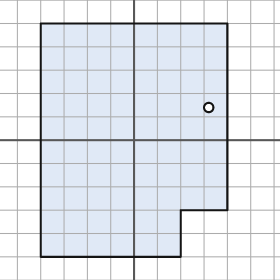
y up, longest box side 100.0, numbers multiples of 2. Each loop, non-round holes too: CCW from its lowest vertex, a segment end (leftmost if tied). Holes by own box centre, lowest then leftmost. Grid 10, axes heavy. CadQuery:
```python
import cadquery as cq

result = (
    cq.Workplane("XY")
    .moveTo(-40.0, -50.0)
    .lineTo(20.0, -50.0)
    .lineTo(20.0, -30.0)
    .lineTo(40.0, -30.0)
    .lineTo(40.0, 50.0)
    .lineTo(-40.0, 50.0)
    .close()
    .moveTo(32.0, 14.0)
    .circle(2.0)
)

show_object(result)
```